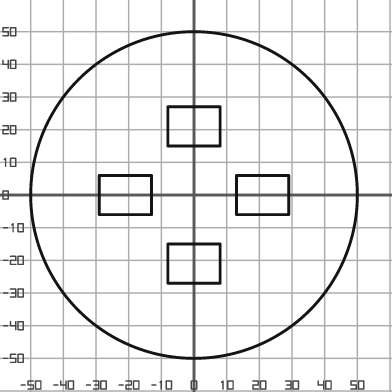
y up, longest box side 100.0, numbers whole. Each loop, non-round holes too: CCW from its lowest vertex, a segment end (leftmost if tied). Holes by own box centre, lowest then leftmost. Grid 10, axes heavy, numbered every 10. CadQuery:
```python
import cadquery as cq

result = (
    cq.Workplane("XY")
    .moveTo(0.0, 0.0)
    .circle(50.0)
    .moveTo(-8.0, -27.0)
    .lineTo(8.0, -27.0)
    .lineTo(8.0, -15.0)
    .lineTo(-8.0, -15.0)
    .close()
    .moveTo(-29.0, -6.0)
    .lineTo(-13.0, -6.0)
    .lineTo(-13.0, 6.0)
    .lineTo(-29.0, 6.0)
    .close()
    .moveTo(13.0, -6.0)
    .lineTo(29.0, -6.0)
    .lineTo(29.0, 6.0)
    .lineTo(13.0, 6.0)
    .close()
    .moveTo(-8.0, 15.0)
    .lineTo(8.0, 15.0)
    .lineTo(8.0, 27.0)
    .lineTo(-8.0, 27.0)
    .close()
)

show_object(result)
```